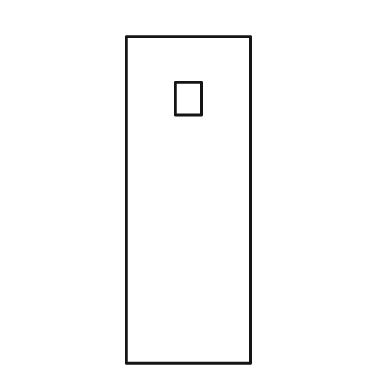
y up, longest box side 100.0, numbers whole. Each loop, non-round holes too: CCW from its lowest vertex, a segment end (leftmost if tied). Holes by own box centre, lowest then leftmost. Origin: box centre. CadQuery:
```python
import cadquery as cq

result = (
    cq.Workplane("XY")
    .moveTo(-19.0, -50.0)
    .lineTo(19.0, -50.0)
    .lineTo(19.0, 50.0)
    .lineTo(-19.0, 50.0)
    .close()
    .moveTo(-4.0, 26.0)
    .lineTo(4.0, 26.0)
    .lineTo(4.0, 36.0)
    .lineTo(-4.0, 36.0)
    .close()
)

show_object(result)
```